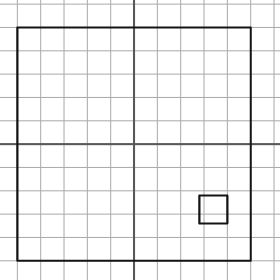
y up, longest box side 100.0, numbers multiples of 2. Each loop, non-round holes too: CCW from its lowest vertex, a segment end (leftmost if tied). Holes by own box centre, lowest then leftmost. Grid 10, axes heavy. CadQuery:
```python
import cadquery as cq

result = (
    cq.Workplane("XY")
    .moveTo(-50.0, -50.0)
    .lineTo(50.0, -50.0)
    .lineTo(50.0, 50.0)
    .lineTo(-50.0, 50.0)
    .close()
    .moveTo(28.0, -34.0)
    .lineTo(40.0, -34.0)
    .lineTo(40.0, -22.0)
    .lineTo(28.0, -22.0)
    .close()
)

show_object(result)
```